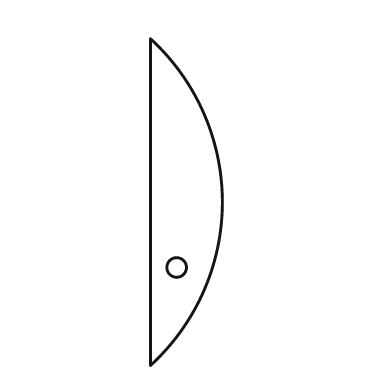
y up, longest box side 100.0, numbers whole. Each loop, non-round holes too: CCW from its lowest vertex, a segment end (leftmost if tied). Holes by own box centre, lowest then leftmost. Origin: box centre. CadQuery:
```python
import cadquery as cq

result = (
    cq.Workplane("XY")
    .moveTo(-11.0, -50.0)
    .threePointArc((11.0, 0.0), (-11.0, 50.0))
    .close()
    .moveTo(-3.0, -20.0)
    .circle(3.0)
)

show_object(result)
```